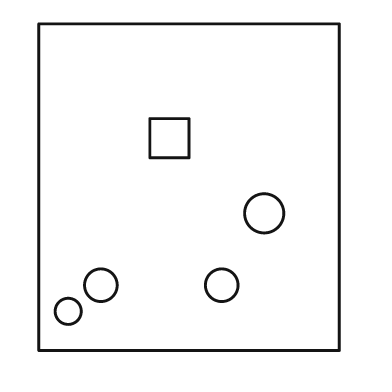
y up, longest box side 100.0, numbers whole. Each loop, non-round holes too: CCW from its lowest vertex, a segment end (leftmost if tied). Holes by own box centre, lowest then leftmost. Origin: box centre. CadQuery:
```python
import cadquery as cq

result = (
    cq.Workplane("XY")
    .moveTo(-46.0, -50.0)
    .lineTo(46.0, -50.0)
    .lineTo(46.0, 50.0)
    .lineTo(-46.0, 50.0)
    .close()
    .moveTo(-37.0, -38.0)
    .circle(4.0)
    .moveTo(-27.0, -30.0)
    .circle(5.0)
    .moveTo(10.0, -30.0)
    .circle(5.0)
    .moveTo(23.0, -8.0)
    .circle(6.0)
    .moveTo(-12.0, 9.0)
    .lineTo(0.0, 9.0)
    .lineTo(0.0, 21.0)
    .lineTo(-12.0, 21.0)
    .close()
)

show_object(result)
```